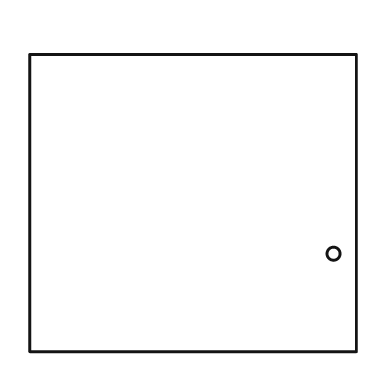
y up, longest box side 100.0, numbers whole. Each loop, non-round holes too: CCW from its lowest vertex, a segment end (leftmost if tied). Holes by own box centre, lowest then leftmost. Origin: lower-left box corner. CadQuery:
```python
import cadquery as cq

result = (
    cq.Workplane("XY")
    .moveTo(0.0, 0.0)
    .lineTo(100.0, 0.0)
    .lineTo(100.0, 91.0)
    .lineTo(0.0, 91.0)
    .close()
    .moveTo(93.0, 30.0)
    .circle(2.0)
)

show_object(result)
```